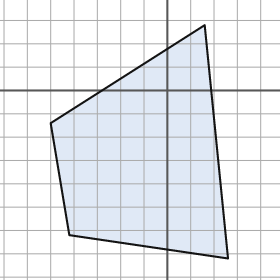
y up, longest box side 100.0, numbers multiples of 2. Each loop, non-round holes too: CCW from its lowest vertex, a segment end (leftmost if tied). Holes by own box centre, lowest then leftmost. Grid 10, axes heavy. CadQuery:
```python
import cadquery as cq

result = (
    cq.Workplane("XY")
    .moveTo(26.0, -72.0)
    .lineTo(16.0, 28.0)
    .lineTo(-50.0, -14.0)
    .lineTo(-42.0, -62.0)
    .close()
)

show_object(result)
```